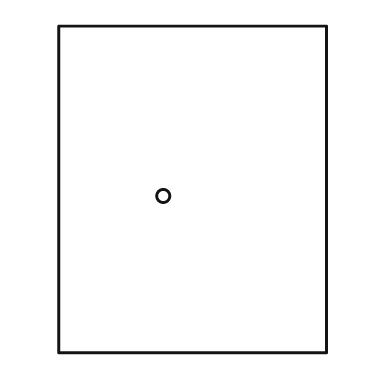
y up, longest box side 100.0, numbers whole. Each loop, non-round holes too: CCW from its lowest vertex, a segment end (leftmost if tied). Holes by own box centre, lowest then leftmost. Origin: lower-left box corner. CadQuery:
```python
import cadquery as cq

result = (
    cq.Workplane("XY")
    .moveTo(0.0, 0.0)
    .lineTo(82.0, 0.0)
    .lineTo(82.0, 100.0)
    .lineTo(0.0, 100.0)
    .close()
    .moveTo(32.0, 48.0)
    .circle(2.0)
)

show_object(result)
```